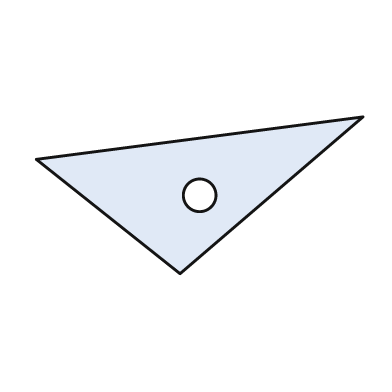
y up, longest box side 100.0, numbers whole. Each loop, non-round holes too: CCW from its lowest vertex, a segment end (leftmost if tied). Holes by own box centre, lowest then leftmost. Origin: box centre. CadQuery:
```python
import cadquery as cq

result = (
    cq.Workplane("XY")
    .moveTo(-6.0, -24.0)
    .lineTo(50.0, 24.0)
    .lineTo(-50.0, 11.0)
    .close()
    .moveTo(0.0, 0.0)
    .circle(5.0)
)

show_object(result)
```